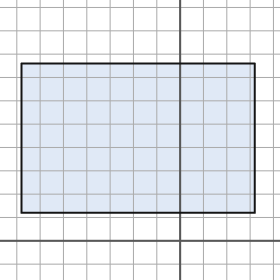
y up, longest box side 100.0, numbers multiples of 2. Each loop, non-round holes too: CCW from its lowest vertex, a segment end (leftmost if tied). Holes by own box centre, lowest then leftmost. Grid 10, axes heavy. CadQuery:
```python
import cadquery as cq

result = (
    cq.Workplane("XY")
    .moveTo(-68.0, 12.0)
    .lineTo(32.0, 12.0)
    .lineTo(32.0, 76.0)
    .lineTo(-68.0, 76.0)
    .close()
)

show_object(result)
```